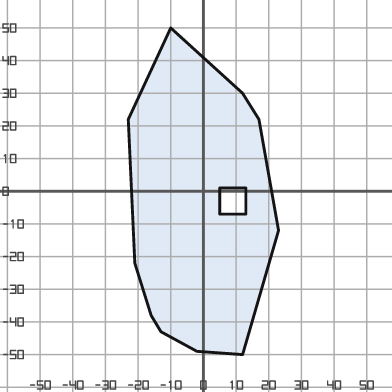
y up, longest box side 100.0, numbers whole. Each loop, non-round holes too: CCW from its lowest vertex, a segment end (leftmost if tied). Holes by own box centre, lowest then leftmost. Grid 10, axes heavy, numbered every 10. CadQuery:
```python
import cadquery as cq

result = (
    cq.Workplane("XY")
    .moveTo(12.0, -50.0)
    .lineTo(23.0, -12.0)
    .lineTo(17.0, 22.0)
    .lineTo(12.0, 30.0)
    .lineTo(-10.0, 50.0)
    .lineTo(-23.0, 22.0)
    .lineTo(-21.0, -22.0)
    .lineTo(-16.0, -38.0)
    .lineTo(-13.0, -43.0)
    .lineTo(-2.0, -49.0)
    .close()
    .moveTo(5.0, -7.0)
    .lineTo(13.0, -7.0)
    .lineTo(13.0, 1.0)
    .lineTo(5.0, 1.0)
    .close()
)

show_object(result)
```